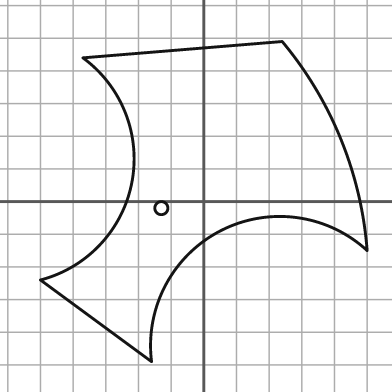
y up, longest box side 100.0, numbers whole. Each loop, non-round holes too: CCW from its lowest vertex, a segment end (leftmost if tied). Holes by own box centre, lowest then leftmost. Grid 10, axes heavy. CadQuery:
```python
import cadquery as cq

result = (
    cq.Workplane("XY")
    .moveTo(-16.0, -49.0)
    .threePointArc((5.0, -9.0), (50.0, -15.0))
    .threePointArc((42.0, 19.0), (24.0, 49.0))
    .lineTo(-37.0, 44.0)
    .threePointArc((-22.0, 6.0), (-50.0, -24.0))
    .close()
    .moveTo(-13.0, -2.0)
    .circle(2.0)
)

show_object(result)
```